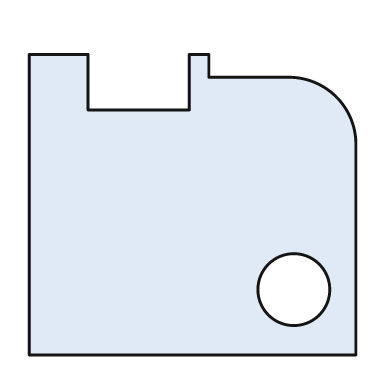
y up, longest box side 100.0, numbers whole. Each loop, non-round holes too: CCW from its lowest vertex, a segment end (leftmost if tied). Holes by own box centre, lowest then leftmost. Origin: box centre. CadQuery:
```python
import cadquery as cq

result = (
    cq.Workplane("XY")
    .moveTo(-50.0, -46.0)
    .lineTo(50.0, -46.0)
    .lineTo(50.0, 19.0)
    .threePointArc((44.0, 33.0), (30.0, 39.0))
    .lineTo(5.0, 39.0)
    .lineTo(5.0, 46.0)
    .lineTo(-1.0, 46.0)
    .lineTo(-1.0, 29.0)
    .lineTo(-32.0, 29.0)
    .lineTo(-32.0, 46.0)
    .lineTo(-50.0, 46.0)
    .close()
    .moveTo(31.0, -26.0)
    .circle(11.0)
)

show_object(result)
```